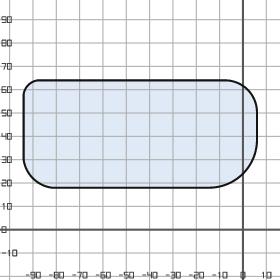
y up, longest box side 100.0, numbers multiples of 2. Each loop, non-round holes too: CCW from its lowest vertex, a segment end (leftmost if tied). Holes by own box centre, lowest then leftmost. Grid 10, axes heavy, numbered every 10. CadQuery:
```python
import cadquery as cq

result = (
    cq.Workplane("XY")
    .moveTo(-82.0, 18.0)
    .lineTo(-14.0, 18.0)
    .threePointArc((0.0, 24.0), (6.0, 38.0))
    .lineTo(6.0, 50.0)
    .threePointArc((2.0, 60.0), (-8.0, 64.0))
    .lineTo(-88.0, 64.0)
    .threePointArc((-92.0, 62.0), (-94.0, 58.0))
    .lineTo(-94.0, 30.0)
    .threePointArc((-90.0, 22.0), (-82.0, 18.0))
    .close()
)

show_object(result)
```